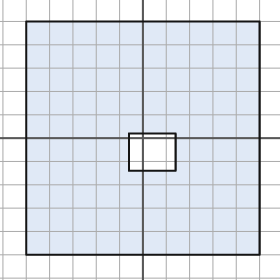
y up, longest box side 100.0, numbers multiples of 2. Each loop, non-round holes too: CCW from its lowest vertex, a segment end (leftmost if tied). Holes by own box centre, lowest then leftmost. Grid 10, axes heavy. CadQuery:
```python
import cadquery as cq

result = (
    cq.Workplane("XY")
    .moveTo(-50.0, -50.0)
    .lineTo(50.0, -50.0)
    .lineTo(50.0, 50.0)
    .lineTo(-50.0, 50.0)
    .close()
    .moveTo(-6.0, -14.0)
    .lineTo(14.0, -14.0)
    .lineTo(14.0, 2.0)
    .lineTo(-6.0, 2.0)
    .close()
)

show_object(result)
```